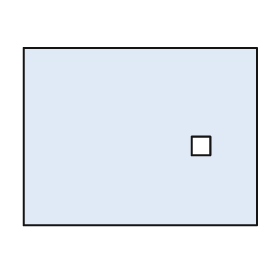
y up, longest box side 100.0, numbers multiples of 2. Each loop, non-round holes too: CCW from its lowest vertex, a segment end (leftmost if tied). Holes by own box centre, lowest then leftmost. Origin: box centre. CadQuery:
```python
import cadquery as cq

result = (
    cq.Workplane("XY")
    .moveTo(-50.0, -38.0)
    .lineTo(50.0, -38.0)
    .lineTo(50.0, 38.0)
    .lineTo(-50.0, 38.0)
    .close()
    .moveTo(22.0, -8.0)
    .lineTo(30.0, -8.0)
    .lineTo(30.0, 0.0)
    .lineTo(22.0, 0.0)
    .close()
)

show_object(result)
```